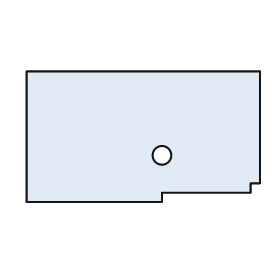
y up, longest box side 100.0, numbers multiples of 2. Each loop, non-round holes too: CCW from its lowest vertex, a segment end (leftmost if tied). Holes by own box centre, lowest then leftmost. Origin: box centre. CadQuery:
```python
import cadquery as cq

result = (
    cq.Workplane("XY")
    .moveTo(-50.0, -28.0)
    .lineTo(8.0, -28.0)
    .lineTo(8.0, -24.0)
    .lineTo(46.0, -24.0)
    .lineTo(46.0, -20.0)
    .lineTo(50.0, -20.0)
    .lineTo(50.0, 28.0)
    .lineTo(-50.0, 28.0)
    .close()
    .moveTo(8.0, -8.0)
    .circle(4.0)
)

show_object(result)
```